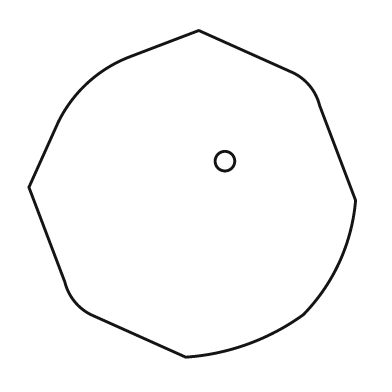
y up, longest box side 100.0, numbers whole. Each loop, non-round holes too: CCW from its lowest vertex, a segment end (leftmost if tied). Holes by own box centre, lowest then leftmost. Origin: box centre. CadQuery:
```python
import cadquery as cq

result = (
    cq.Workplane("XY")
    .moveTo(-2.0, -50.0)
    .threePointArc((17.0, -46.0), (34.0, -37.0))
    .threePointArc((45.0, -21.0), (50.0, -2.0))
    .lineTo(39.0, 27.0)
    .threePointArc((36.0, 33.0), (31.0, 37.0))
    .lineTo(2.0, 50.0)
    .lineTo(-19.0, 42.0)
    .threePointArc((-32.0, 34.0), (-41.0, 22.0))
    .lineTo(-50.0, 2.0)
    .lineTo(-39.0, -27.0)
    .threePointArc((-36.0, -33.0), (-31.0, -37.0))
    .close()
    .moveTo(10.0, 10.0)
    .circle(3.0)
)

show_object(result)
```